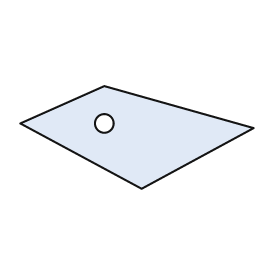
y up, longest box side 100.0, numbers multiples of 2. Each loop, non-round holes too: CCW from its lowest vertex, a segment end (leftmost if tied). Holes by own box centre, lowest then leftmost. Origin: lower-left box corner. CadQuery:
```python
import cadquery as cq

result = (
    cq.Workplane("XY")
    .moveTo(52.0, 0.0)
    .lineTo(100.0, 26.0)
    .lineTo(36.0, 44.0)
    .lineTo(0.0, 28.0)
    .close()
    .moveTo(36.0, 28.0)
    .circle(4.0)
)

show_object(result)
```